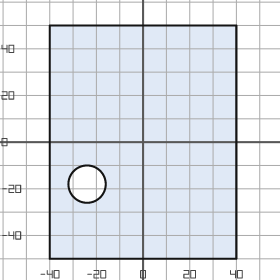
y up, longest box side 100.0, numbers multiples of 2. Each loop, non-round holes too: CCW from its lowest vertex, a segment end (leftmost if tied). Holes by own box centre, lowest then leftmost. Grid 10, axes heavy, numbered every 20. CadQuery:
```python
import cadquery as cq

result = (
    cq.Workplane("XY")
    .moveTo(-40.0, -50.0)
    .lineTo(40.0, -50.0)
    .lineTo(40.0, 50.0)
    .lineTo(-40.0, 50.0)
    .close()
    .moveTo(-24.0, -18.0)
    .circle(8.0)
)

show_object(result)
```